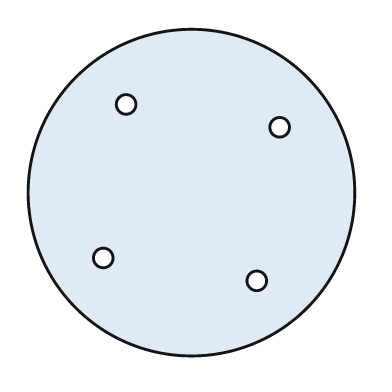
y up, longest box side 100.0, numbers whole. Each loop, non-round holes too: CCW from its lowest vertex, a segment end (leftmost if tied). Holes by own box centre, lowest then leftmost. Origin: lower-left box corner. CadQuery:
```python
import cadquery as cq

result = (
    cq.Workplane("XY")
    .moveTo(50.0, 50.0)
    .circle(50.0)
    .moveTo(70.0, 23.0)
    .circle(3.0)
    .moveTo(23.0, 30.0)
    .circle(3.0)
    .moveTo(77.0, 70.0)
    .circle(3.0)
    .moveTo(30.0, 77.0)
    .circle(3.0)
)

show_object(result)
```